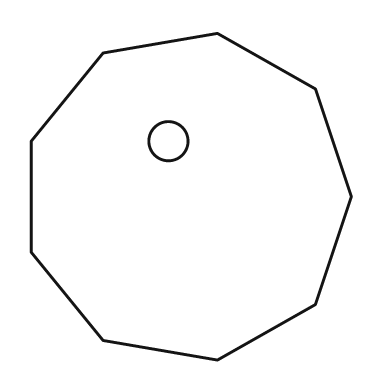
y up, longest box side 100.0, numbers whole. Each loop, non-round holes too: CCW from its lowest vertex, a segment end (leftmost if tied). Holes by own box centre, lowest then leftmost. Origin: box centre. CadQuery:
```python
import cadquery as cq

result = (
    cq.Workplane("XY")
    .moveTo(8.0, -50.0)
    .lineTo(38.0, -33.0)
    .lineTo(49.0, 0.0)
    .lineTo(38.0, 33.0)
    .lineTo(8.0, 50.0)
    .lineTo(-27.0, 44.0)
    .lineTo(-49.0, 17.0)
    .lineTo(-49.0, -17.0)
    .lineTo(-27.0, -44.0)
    .close()
    .moveTo(-7.0, 17.0)
    .circle(6.0)
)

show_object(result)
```